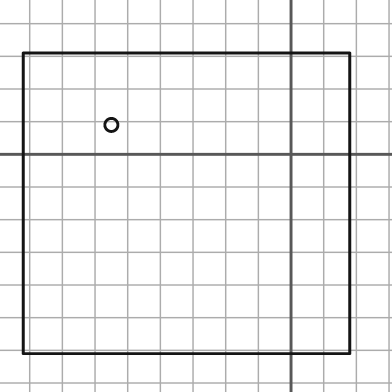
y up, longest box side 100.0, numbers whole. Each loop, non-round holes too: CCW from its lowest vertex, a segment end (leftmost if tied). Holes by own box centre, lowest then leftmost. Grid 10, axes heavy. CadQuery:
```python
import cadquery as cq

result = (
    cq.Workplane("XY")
    .moveTo(-82.0, -61.0)
    .lineTo(18.0, -61.0)
    .lineTo(18.0, 31.0)
    .lineTo(-82.0, 31.0)
    .close()
    .moveTo(-55.0, 9.0)
    .circle(2.0)
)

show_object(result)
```